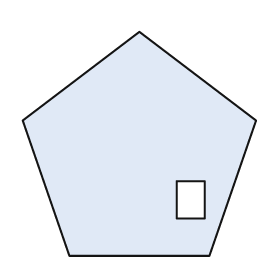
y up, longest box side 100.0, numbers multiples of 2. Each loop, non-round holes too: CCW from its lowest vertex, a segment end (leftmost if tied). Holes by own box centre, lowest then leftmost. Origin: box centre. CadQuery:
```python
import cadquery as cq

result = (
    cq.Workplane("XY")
    .moveTo(-30.0, -48.0)
    .lineTo(30.0, -48.0)
    .lineTo(50.0, 10.0)
    .lineTo(0.0, 48.0)
    .lineTo(-50.0, 10.0)
    .close()
    .moveTo(16.0, -32.0)
    .lineTo(28.0, -32.0)
    .lineTo(28.0, -16.0)
    .lineTo(16.0, -16.0)
    .close()
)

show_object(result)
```